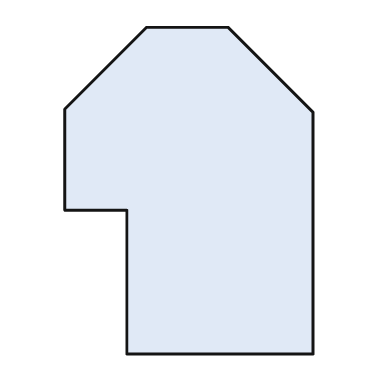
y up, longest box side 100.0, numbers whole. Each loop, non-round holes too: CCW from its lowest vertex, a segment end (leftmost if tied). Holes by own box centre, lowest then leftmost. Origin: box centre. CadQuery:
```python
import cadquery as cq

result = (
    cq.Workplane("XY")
    .moveTo(-19.0, -50.0)
    .lineTo(38.0, -50.0)
    .lineTo(38.0, 24.0)
    .lineTo(12.0, 50.0)
    .lineTo(-13.0, 50.0)
    .lineTo(-38.0, 25.0)
    .lineTo(-38.0, -6.0)
    .lineTo(-19.0, -6.0)
    .close()
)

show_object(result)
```